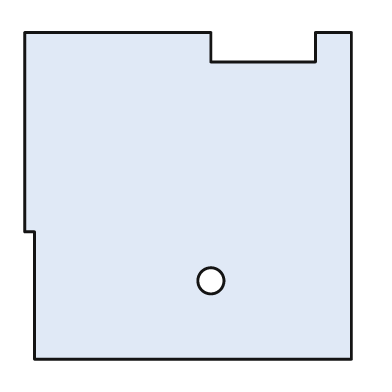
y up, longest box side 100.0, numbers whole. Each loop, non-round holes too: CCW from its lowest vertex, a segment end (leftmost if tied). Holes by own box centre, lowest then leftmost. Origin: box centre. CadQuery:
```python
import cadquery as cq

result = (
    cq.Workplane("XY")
    .moveTo(-47.0, -50.0)
    .lineTo(50.0, -50.0)
    .lineTo(50.0, 50.0)
    .lineTo(39.0, 50.0)
    .lineTo(39.0, 41.0)
    .lineTo(7.0, 41.0)
    .lineTo(7.0, 50.0)
    .lineTo(-50.0, 50.0)
    .lineTo(-50.0, -11.0)
    .lineTo(-47.0, -11.0)
    .close()
    .moveTo(7.0, -26.0)
    .circle(4.0)
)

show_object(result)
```